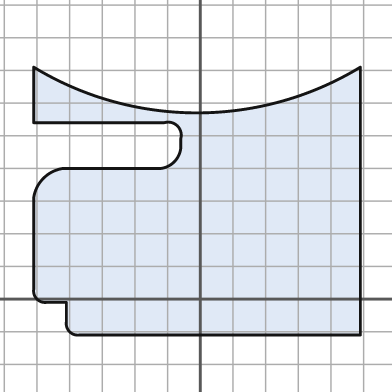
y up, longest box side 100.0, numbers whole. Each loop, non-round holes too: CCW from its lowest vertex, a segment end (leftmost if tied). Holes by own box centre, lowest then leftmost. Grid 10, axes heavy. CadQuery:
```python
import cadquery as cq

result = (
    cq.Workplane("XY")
    .moveTo(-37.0, -11.0)
    .lineTo(49.0, -11.0)
    .lineTo(49.0, 71.0)
    .threePointArc((-1.0, 57.0), (-51.0, 71.0))
    .lineTo(-51.0, 54.0)
    .lineTo(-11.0, 54.0)
    .threePointArc((-7.0, 53.0), (-6.0, 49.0))
    .lineTo(-6.0, 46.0)
    .threePointArc((-8.0, 42.0), (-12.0, 40.0))
    .lineTo(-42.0, 40.0)
    .threePointArc((-48.0, 37.0), (-51.0, 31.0))
    .lineTo(-51.0, 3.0)
    .threePointArc((-50.0, 0.0), (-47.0, -1.0))
    .lineTo(-41.0, -1.0)
    .lineTo(-41.0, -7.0)
    .threePointArc((-40.0, -10.0), (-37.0, -11.0))
    .close()
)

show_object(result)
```